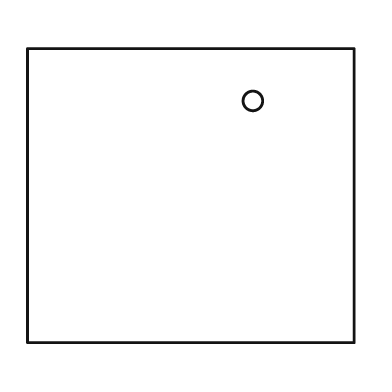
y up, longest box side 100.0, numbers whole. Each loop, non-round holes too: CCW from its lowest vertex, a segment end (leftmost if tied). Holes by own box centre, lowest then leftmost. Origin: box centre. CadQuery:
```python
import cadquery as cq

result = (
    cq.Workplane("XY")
    .moveTo(-50.0, -45.0)
    .lineTo(50.0, -45.0)
    .lineTo(50.0, 45.0)
    .lineTo(-50.0, 45.0)
    .close()
    .moveTo(19.0, 29.0)
    .circle(3.0)
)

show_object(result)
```